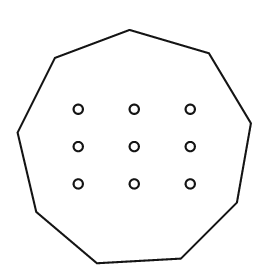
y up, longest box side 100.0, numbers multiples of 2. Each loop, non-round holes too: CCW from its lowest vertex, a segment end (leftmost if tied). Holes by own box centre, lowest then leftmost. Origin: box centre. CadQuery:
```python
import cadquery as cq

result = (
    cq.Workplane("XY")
    .moveTo(-16.0, -50.0)
    .lineTo(20.0, -48.0)
    .lineTo(44.0, -24.0)
    .lineTo(50.0, 10.0)
    .lineTo(32.0, 40.0)
    .lineTo(-2.0, 50.0)
    .lineTo(-34.0, 38.0)
    .lineTo(-50.0, 6.0)
    .lineTo(-42.0, -28.0)
    .close()
    .moveTo(-24.0, -16.0)
    .circle(2.0)
    .moveTo(0.0, -16.0)
    .circle(2.0)
    .moveTo(24.0, -16.0)
    .circle(2.0)
    .moveTo(-24.0, 0.0)
    .circle(2.0)
    .moveTo(0.0, 0.0)
    .circle(2.0)
    .moveTo(24.0, 0.0)
    .circle(2.0)
    .moveTo(-24.0, 16.0)
    .circle(2.0)
    .moveTo(0.0, 16.0)
    .circle(2.0)
    .moveTo(24.0, 16.0)
    .circle(2.0)
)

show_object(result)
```